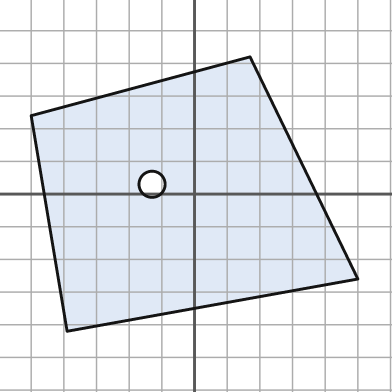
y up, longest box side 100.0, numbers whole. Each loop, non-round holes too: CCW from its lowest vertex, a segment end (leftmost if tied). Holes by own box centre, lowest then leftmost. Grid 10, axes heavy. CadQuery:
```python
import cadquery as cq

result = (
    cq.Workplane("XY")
    .moveTo(-39.0, -42.0)
    .lineTo(50.0, -26.0)
    .lineTo(17.0, 42.0)
    .lineTo(-50.0, 24.0)
    .close()
    .moveTo(-13.0, 3.0)
    .circle(4.0)
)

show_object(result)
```